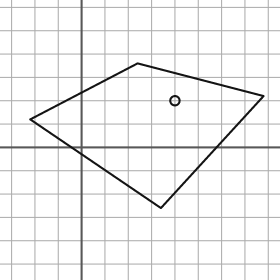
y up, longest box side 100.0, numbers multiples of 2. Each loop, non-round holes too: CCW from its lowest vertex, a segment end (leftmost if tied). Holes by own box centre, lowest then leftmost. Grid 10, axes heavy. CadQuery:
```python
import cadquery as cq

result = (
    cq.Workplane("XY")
    .moveTo(34.0, -26.0)
    .lineTo(78.0, 22.0)
    .lineTo(24.0, 36.0)
    .lineTo(-22.0, 12.0)
    .close()
    .moveTo(40.0, 20.0)
    .circle(2.0)
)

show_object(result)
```